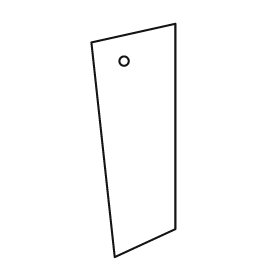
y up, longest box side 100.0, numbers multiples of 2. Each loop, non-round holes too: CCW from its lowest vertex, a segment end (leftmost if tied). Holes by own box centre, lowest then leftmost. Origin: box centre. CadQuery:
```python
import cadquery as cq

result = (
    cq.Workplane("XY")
    .moveTo(-8.0, -50.0)
    .lineTo(18.0, -38.0)
    .lineTo(18.0, 50.0)
    .lineTo(-18.0, 42.0)
    .close()
    .moveTo(-4.0, 34.0)
    .circle(2.0)
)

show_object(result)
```